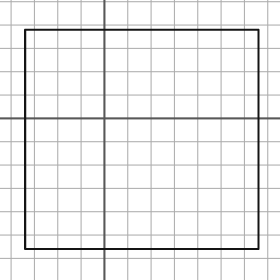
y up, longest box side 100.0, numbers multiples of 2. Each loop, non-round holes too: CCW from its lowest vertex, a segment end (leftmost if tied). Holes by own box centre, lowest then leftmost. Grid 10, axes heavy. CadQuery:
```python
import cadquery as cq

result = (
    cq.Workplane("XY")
    .moveTo(-34.0, -56.0)
    .lineTo(66.0, -56.0)
    .lineTo(66.0, 38.0)
    .lineTo(-34.0, 38.0)
    .close()
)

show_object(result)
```